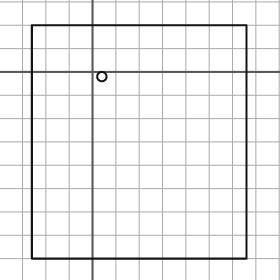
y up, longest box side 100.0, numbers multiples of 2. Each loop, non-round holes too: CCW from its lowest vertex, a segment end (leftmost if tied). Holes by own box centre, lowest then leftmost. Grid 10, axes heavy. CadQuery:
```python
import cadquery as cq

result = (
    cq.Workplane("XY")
    .moveTo(-26.0, -80.0)
    .lineTo(66.0, -80.0)
    .lineTo(66.0, 20.0)
    .lineTo(-26.0, 20.0)
    .close()
    .moveTo(4.0, -2.0)
    .circle(2.0)
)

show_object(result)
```